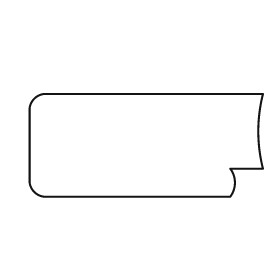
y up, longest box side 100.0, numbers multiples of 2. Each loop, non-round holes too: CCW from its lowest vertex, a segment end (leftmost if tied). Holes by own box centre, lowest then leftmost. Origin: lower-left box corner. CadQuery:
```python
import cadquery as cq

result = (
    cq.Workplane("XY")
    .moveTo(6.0, 0.0)
    .lineTo(86.0, 0.0)
    .threePointArc((88.0, 6.0), (86.0, 12.0))
    .lineTo(100.0, 12.0)
    .threePointArc((98.0, 28.0), (100.0, 44.0))
    .lineTo(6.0, 44.0)
    .threePointArc((2.0, 42.0), (0.0, 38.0))
    .lineTo(0.0, 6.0)
    .threePointArc((2.0, 2.0), (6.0, 0.0))
    .close()
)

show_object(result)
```